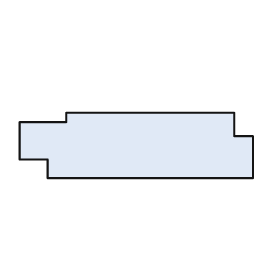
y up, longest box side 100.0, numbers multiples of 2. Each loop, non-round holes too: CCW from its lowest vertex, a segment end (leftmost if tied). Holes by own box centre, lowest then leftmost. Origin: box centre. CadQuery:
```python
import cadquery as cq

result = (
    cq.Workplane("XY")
    .moveTo(-38.0, -14.0)
    .lineTo(50.0, -14.0)
    .lineTo(50.0, 4.0)
    .lineTo(42.0, 4.0)
    .lineTo(42.0, 14.0)
    .lineTo(-30.0, 14.0)
    .lineTo(-30.0, 10.0)
    .lineTo(-50.0, 10.0)
    .lineTo(-50.0, -6.0)
    .lineTo(-38.0, -6.0)
    .close()
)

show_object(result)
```